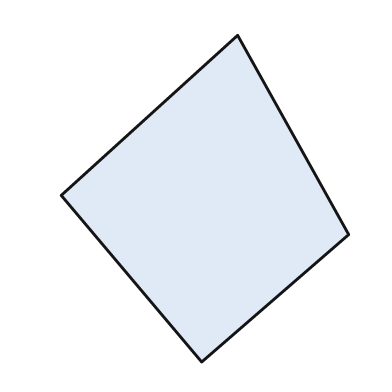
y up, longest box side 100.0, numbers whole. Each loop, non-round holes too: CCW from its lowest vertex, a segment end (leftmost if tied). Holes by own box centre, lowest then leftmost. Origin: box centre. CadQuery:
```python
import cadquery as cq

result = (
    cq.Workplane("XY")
    .moveTo(-1.0, -50.0)
    .lineTo(44.0, -11.0)
    .lineTo(10.0, 50.0)
    .lineTo(-44.0, 1.0)
    .close()
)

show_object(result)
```